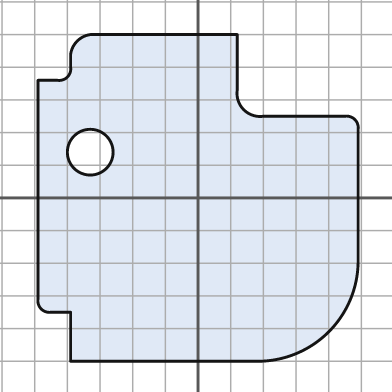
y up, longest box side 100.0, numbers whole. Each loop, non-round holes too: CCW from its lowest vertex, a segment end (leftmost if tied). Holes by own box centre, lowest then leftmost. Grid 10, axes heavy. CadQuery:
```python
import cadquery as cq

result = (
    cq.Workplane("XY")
    .moveTo(-39.0, -50.0)
    .lineTo(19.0, -50.0)
    .threePointArc((40.0, -41.0), (49.0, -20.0))
    .lineTo(49.0, 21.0)
    .threePointArc((48.0, 24.0), (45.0, 25.0))
    .lineTo(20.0, 25.0)
    .threePointArc((14.0, 27.0), (12.0, 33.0))
    .lineTo(12.0, 50.0)
    .lineTo(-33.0, 50.0)
    .threePointArc((-37.0, 48.0), (-39.0, 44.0))
    .lineTo(-39.0, 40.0)
    .threePointArc((-40.0, 37.0), (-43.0, 36.0))
    .lineTo(-49.0, 36.0)
    .lineTo(-49.0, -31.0)
    .threePointArc((-48.0, -34.0), (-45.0, -35.0))
    .lineTo(-39.0, -35.0)
    .close()
    .moveTo(-33.0, 14.0)
    .circle(7.0)
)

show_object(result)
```